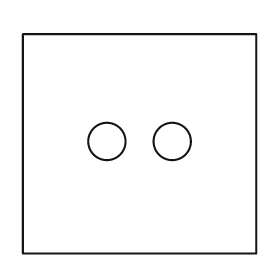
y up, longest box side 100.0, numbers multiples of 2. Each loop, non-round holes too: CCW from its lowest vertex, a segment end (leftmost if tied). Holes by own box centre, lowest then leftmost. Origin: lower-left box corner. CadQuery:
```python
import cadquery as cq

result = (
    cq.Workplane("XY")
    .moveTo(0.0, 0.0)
    .lineTo(100.0, 0.0)
    .lineTo(100.0, 94.0)
    .lineTo(0.0, 94.0)
    .close()
    .moveTo(36.0, 48.0)
    .circle(8.0)
    .moveTo(64.0, 48.0)
    .circle(8.0)
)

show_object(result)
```